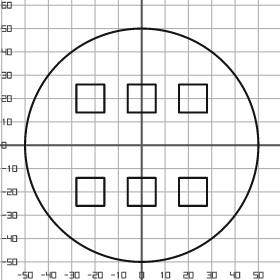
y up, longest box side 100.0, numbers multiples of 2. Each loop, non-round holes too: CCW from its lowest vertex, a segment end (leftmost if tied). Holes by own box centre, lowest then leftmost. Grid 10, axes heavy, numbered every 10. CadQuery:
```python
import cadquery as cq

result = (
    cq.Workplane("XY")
    .moveTo(0.0, 0.0)
    .circle(50.0)
    .moveTo(-28.0, -26.0)
    .lineTo(-16.0, -26.0)
    .lineTo(-16.0, -14.0)
    .lineTo(-28.0, -14.0)
    .close()
    .moveTo(-6.0, -26.0)
    .lineTo(6.0, -26.0)
    .lineTo(6.0, -14.0)
    .lineTo(-6.0, -14.0)
    .close()
    .moveTo(16.0, -26.0)
    .lineTo(28.0, -26.0)
    .lineTo(28.0, -14.0)
    .lineTo(16.0, -14.0)
    .close()
    .moveTo(-28.0, 14.0)
    .lineTo(-16.0, 14.0)
    .lineTo(-16.0, 26.0)
    .lineTo(-28.0, 26.0)
    .close()
    .moveTo(-6.0, 14.0)
    .lineTo(6.0, 14.0)
    .lineTo(6.0, 26.0)
    .lineTo(-6.0, 26.0)
    .close()
    .moveTo(16.0, 14.0)
    .lineTo(28.0, 14.0)
    .lineTo(28.0, 26.0)
    .lineTo(16.0, 26.0)
    .close()
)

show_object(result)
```